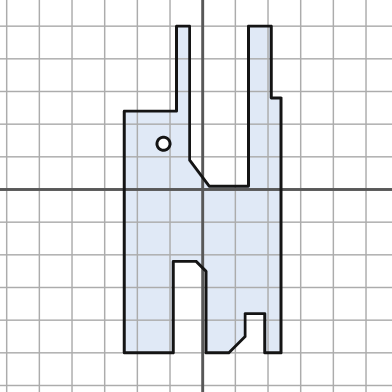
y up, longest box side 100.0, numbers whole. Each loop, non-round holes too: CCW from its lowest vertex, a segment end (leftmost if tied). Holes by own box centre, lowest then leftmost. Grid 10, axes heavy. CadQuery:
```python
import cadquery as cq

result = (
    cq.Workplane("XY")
    .moveTo(-24.0, -50.0)
    .lineTo(-9.0, -50.0)
    .lineTo(-9.0, -22.0)
    .lineTo(-2.0, -22.0)
    .lineTo(1.0, -25.0)
    .lineTo(1.0, -50.0)
    .lineTo(8.0, -50.0)
    .lineTo(13.0, -45.0)
    .lineTo(13.0, -38.0)
    .lineTo(19.0, -38.0)
    .lineTo(19.0, -50.0)
    .lineTo(24.0, -50.0)
    .lineTo(24.0, 28.0)
    .lineTo(21.0, 28.0)
    .lineTo(21.0, 50.0)
    .lineTo(14.0, 50.0)
    .lineTo(14.0, 1.0)
    .lineTo(2.0, 1.0)
    .lineTo(-4.0, 9.0)
    .lineTo(-4.0, 50.0)
    .lineTo(-8.0, 50.0)
    .lineTo(-8.0, 24.0)
    .lineTo(-24.0, 24.0)
    .close()
    .moveTo(-12.0, 14.0)
    .circle(2.0)
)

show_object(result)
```